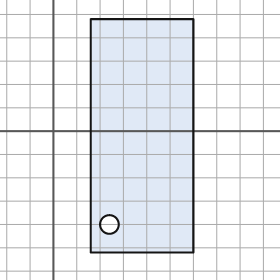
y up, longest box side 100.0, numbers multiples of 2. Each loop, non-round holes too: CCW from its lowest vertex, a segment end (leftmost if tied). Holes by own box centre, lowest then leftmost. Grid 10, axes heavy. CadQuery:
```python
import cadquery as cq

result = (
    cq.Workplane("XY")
    .moveTo(16.0, -52.0)
    .lineTo(60.0, -52.0)
    .lineTo(60.0, 48.0)
    .lineTo(16.0, 48.0)
    .close()
    .moveTo(24.0, -40.0)
    .circle(4.0)
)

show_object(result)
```